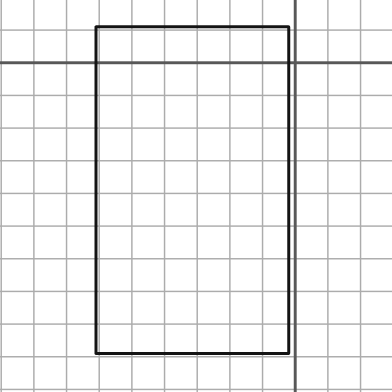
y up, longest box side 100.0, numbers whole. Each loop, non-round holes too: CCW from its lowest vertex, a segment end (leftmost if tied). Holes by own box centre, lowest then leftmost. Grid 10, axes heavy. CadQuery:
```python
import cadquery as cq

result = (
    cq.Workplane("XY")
    .moveTo(-61.0, -89.0)
    .lineTo(-2.0, -89.0)
    .lineTo(-2.0, 11.0)
    .lineTo(-61.0, 11.0)
    .close()
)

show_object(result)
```